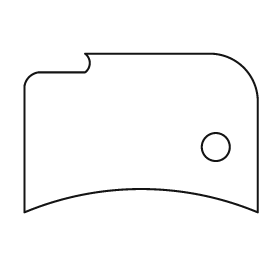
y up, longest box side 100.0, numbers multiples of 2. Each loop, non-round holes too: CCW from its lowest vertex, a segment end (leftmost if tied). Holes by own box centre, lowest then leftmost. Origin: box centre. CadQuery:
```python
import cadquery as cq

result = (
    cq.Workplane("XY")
    .moveTo(-50.0, -34.0)
    .threePointArc((0.0, -24.0), (50.0, -34.0))
    .lineTo(50.0, 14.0)
    .threePointArc((44.0, 28.0), (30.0, 34.0))
    .lineTo(-24.0, 34.0)
    .threePointArc((-22.0, 30.0), (-24.0, 26.0))
    .lineTo(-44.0, 26.0)
    .threePointArc((-48.0, 24.0), (-50.0, 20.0))
    .close()
    .moveTo(32.0, -6.0)
    .circle(6.0)
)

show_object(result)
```